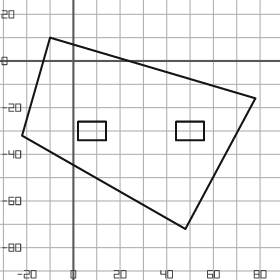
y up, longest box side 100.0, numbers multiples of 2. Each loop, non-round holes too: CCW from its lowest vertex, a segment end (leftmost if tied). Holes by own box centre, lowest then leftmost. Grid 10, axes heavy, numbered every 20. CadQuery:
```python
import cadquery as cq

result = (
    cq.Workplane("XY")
    .moveTo(48.0, -72.0)
    .lineTo(78.0, -16.0)
    .lineTo(-10.0, 10.0)
    .lineTo(-22.0, -32.0)
    .close()
    .moveTo(2.0, -34.0)
    .lineTo(14.0, -34.0)
    .lineTo(14.0, -26.0)
    .lineTo(2.0, -26.0)
    .close()
    .moveTo(44.0, -34.0)
    .lineTo(56.0, -34.0)
    .lineTo(56.0, -26.0)
    .lineTo(44.0, -26.0)
    .close()
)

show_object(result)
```